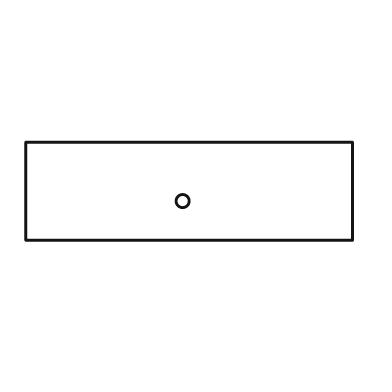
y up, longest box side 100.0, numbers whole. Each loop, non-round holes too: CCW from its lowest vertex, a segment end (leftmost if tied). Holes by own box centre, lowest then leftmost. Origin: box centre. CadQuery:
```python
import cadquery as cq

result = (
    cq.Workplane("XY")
    .moveTo(-50.0, -15.0)
    .lineTo(50.0, -15.0)
    .lineTo(50.0, 15.0)
    .lineTo(-50.0, 15.0)
    .close()
    .moveTo(-2.0, -3.0)
    .circle(2.0)
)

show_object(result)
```